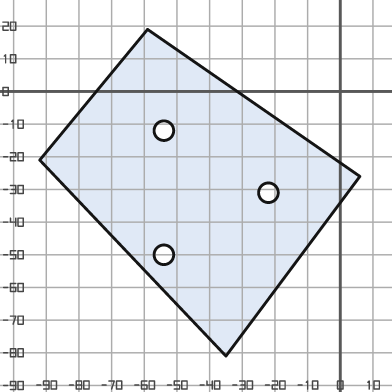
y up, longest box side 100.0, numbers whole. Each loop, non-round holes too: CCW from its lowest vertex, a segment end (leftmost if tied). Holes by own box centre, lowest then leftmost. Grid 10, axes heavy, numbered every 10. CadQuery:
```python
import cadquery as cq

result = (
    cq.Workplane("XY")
    .moveTo(-35.0, -81.0)
    .lineTo(6.0, -26.0)
    .lineTo(-59.0, 19.0)
    .lineTo(-92.0, -21.0)
    .close()
    .moveTo(-54.0, -50.0)
    .circle(3.0)
    .moveTo(-22.0, -31.0)
    .circle(3.0)
    .moveTo(-54.0, -12.0)
    .circle(3.0)
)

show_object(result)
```